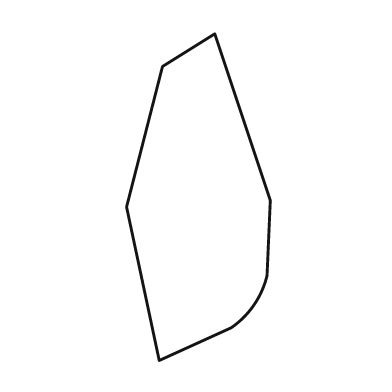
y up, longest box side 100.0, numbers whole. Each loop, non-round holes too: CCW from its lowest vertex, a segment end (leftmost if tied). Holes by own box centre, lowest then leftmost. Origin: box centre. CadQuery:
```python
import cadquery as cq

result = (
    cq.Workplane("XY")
    .moveTo(-12.0, -50.0)
    .lineTo(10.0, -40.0)
    .threePointArc((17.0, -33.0), (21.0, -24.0))
    .lineTo(22.0, -1.0)
    .lineTo(5.0, 50.0)
    .lineTo(-11.0, 40.0)
    .lineTo(-22.0, -3.0)
    .close()
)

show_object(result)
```